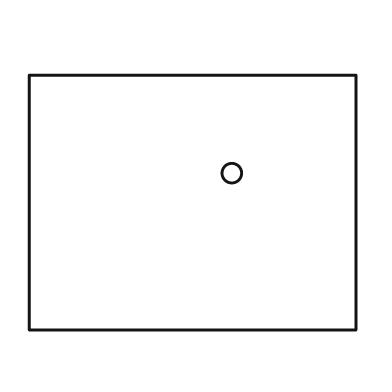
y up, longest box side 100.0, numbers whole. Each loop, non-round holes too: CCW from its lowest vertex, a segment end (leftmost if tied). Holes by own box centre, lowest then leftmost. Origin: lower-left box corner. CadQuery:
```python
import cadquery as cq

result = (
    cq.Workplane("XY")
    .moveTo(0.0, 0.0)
    .lineTo(100.0, 0.0)
    .lineTo(100.0, 78.0)
    .lineTo(0.0, 78.0)
    .close()
    .moveTo(62.0, 48.0)
    .circle(3.0)
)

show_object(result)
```